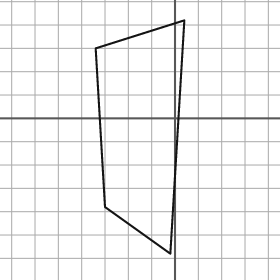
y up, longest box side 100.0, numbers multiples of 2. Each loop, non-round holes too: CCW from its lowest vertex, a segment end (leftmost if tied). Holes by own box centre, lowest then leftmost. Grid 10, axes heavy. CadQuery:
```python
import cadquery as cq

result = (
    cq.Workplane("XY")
    .moveTo(-2.0, -58.0)
    .lineTo(4.0, 42.0)
    .lineTo(-34.0, 30.0)
    .lineTo(-30.0, -38.0)
    .close()
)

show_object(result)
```